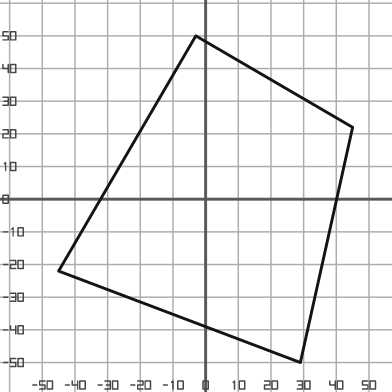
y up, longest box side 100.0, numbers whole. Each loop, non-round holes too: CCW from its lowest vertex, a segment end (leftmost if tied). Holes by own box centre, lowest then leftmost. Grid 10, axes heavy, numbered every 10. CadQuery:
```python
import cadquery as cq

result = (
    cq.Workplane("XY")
    .moveTo(29.0, -50.0)
    .lineTo(45.0, 22.0)
    .lineTo(-3.0, 50.0)
    .lineTo(-45.0, -22.0)
    .close()
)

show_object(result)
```